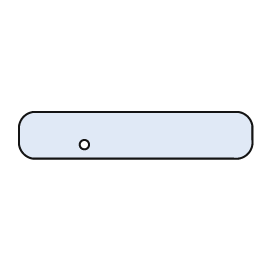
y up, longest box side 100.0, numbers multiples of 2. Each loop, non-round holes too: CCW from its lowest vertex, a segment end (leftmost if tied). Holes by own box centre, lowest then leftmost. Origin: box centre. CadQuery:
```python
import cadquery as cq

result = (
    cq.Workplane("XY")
    .moveTo(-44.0, -10.0)
    .lineTo(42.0, -10.0)
    .threePointArc((48.0, -8.0), (50.0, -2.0))
    .lineTo(50.0, 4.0)
    .threePointArc((48.0, 8.0), (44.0, 10.0))
    .lineTo(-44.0, 10.0)
    .threePointArc((-48.0, 8.0), (-50.0, 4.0))
    .lineTo(-50.0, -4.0)
    .threePointArc((-48.0, -8.0), (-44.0, -10.0))
    .close()
    .moveTo(-22.0, -4.0)
    .circle(2.0)
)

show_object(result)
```